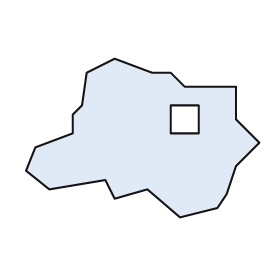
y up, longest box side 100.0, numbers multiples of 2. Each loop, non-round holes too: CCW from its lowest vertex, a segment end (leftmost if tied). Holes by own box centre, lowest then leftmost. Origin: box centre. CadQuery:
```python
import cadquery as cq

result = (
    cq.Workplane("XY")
    .moveTo(16.0, -34.0)
    .lineTo(32.0, -30.0)
    .lineTo(36.0, -24.0)
    .lineTo(40.0, -12.0)
    .lineTo(50.0, -2.0)
    .lineTo(40.0, 8.0)
    .lineTo(40.0, 22.0)
    .lineTo(18.0, 22.0)
    .lineTo(12.0, 28.0)
    .lineTo(4.0, 28.0)
    .lineTo(-12.0, 34.0)
    .lineTo(-24.0, 28.0)
    .lineTo(-26.0, 14.0)
    .lineTo(-30.0, 10.0)
    .lineTo(-30.0, 2.0)
    .lineTo(-46.0, -4.0)
    .lineTo(-50.0, -14.0)
    .lineTo(-40.0, -22.0)
    .lineTo(-16.0, -18.0)
    .lineTo(-12.0, -26.0)
    .lineTo(2.0, -22.0)
    .close()
    .moveTo(12.0, 2.0)
    .lineTo(24.0, 2.0)
    .lineTo(24.0, 14.0)
    .lineTo(12.0, 14.0)
    .close()
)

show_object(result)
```